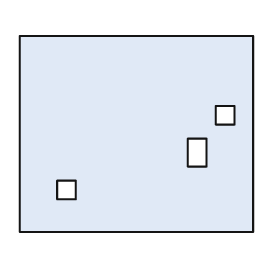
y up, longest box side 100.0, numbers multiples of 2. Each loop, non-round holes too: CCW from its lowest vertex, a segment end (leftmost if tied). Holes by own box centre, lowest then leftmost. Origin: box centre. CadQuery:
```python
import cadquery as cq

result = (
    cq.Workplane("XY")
    .moveTo(-50.0, -42.0)
    .lineTo(50.0, -42.0)
    .lineTo(50.0, 42.0)
    .lineTo(-50.0, 42.0)
    .close()
    .moveTo(-34.0, -28.0)
    .lineTo(-26.0, -28.0)
    .lineTo(-26.0, -20.0)
    .lineTo(-34.0, -20.0)
    .close()
    .moveTo(22.0, -14.0)
    .lineTo(30.0, -14.0)
    .lineTo(30.0, -2.0)
    .lineTo(22.0, -2.0)
    .close()
    .moveTo(34.0, 4.0)
    .lineTo(42.0, 4.0)
    .lineTo(42.0, 12.0)
    .lineTo(34.0, 12.0)
    .close()
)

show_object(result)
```